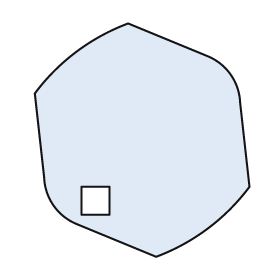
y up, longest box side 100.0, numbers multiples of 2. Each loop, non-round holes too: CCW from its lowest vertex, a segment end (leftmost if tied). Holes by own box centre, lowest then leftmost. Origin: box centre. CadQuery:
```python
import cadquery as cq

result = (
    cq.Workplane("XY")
    .moveTo(6.0, -50.0)
    .threePointArc((28.0, -38.0), (46.0, -20.0))
    .lineTo(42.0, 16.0)
    .threePointArc((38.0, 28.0), (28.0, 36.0))
    .lineTo(-6.0, 50.0)
    .threePointArc((-28.0, 38.0), (-46.0, 20.0))
    .lineTo(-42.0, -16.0)
    .threePointArc((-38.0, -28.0), (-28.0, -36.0))
    .close()
    .moveTo(-26.0, -32.0)
    .lineTo(-14.0, -32.0)
    .lineTo(-14.0, -20.0)
    .lineTo(-26.0, -20.0)
    .close()
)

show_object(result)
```